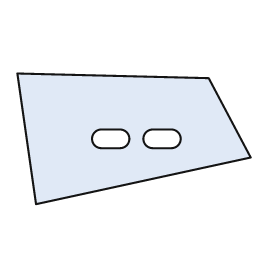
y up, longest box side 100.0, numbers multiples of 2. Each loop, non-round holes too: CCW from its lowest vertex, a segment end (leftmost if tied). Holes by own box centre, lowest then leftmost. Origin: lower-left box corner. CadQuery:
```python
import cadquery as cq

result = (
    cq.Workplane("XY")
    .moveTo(8.0, 0.0)
    .lineTo(100.0, 20.0)
    .lineTo(82.0, 54.0)
    .lineTo(0.0, 56.0)
    .close()
    .moveTo(36.0, 24.0)
    .lineTo(44.0, 24.0)
    .threePointArc((48.0, 28.0), (44.0, 32.0))
    .lineTo(36.0, 32.0)
    .threePointArc((32.0, 28.0), (36.0, 24.0))
    .close()
    .moveTo(58.0, 24.0)
    .lineTo(66.0, 24.0)
    .threePointArc((70.0, 28.0), (66.0, 32.0))
    .lineTo(58.0, 32.0)
    .threePointArc((54.0, 28.0), (58.0, 24.0))
    .close()
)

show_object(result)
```